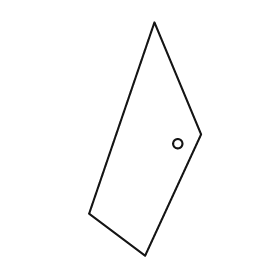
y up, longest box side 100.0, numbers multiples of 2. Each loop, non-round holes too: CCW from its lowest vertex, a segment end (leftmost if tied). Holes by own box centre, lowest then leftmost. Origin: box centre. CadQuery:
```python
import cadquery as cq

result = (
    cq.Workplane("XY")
    .moveTo(0.0, -50.0)
    .lineTo(24.0, 2.0)
    .lineTo(4.0, 50.0)
    .lineTo(-24.0, -32.0)
    .close()
    .moveTo(14.0, -2.0)
    .circle(2.0)
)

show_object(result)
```